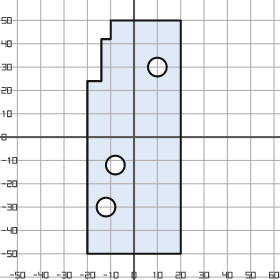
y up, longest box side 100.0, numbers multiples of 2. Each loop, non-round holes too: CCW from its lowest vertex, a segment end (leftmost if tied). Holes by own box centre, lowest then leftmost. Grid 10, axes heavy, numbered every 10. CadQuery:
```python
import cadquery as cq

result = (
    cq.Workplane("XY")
    .moveTo(-20.0, -50.0)
    .lineTo(20.0, -50.0)
    .lineTo(20.0, 50.0)
    .lineTo(-10.0, 50.0)
    .lineTo(-10.0, 42.0)
    .lineTo(-14.0, 42.0)
    .lineTo(-14.0, 24.0)
    .lineTo(-20.0, 24.0)
    .close()
    .moveTo(-12.0, -30.0)
    .circle(4.0)
    .moveTo(-8.0, -12.0)
    .circle(4.0)
    .moveTo(10.0, 30.0)
    .circle(4.0)
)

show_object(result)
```